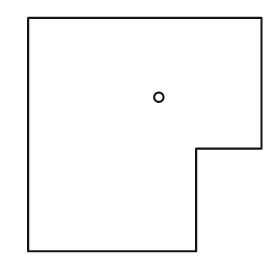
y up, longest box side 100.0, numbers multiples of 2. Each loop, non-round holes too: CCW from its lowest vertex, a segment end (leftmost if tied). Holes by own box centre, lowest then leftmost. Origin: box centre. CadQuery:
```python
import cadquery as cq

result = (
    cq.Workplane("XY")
    .moveTo(-50.0, -50.0)
    .lineTo(22.0, -50.0)
    .lineTo(22.0, -6.0)
    .lineTo(50.0, -6.0)
    .lineTo(50.0, 50.0)
    .lineTo(-50.0, 50.0)
    .close()
    .moveTo(6.0, 16.0)
    .circle(2.0)
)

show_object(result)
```